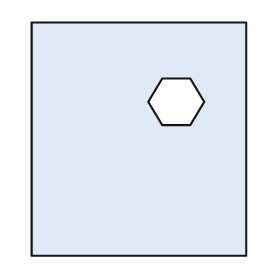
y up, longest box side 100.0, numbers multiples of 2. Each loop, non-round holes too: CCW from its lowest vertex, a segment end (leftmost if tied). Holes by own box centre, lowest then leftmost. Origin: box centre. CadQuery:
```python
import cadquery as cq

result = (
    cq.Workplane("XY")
    .moveTo(-46.0, -50.0)
    .lineTo(46.0, -50.0)
    .lineTo(46.0, 50.0)
    .lineTo(-46.0, 50.0)
    .close()
    .moveTo(10.0, 6.0)
    .lineTo(22.0, 6.0)
    .lineTo(28.0, 16.0)
    .lineTo(22.0, 26.0)
    .lineTo(10.0, 26.0)
    .lineTo(4.0, 16.0)
    .close()
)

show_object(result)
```